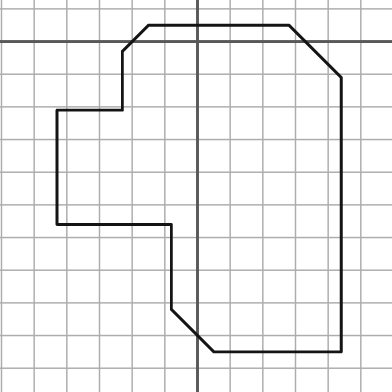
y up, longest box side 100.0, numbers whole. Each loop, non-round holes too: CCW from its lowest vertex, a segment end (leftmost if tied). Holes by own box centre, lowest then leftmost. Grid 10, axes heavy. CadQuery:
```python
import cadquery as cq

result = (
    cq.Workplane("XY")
    .moveTo(5.0, -95.0)
    .lineTo(44.0, -95.0)
    .lineTo(44.0, -11.0)
    .lineTo(28.0, 5.0)
    .lineTo(-15.0, 5.0)
    .lineTo(-23.0, -3.0)
    .lineTo(-23.0, -21.0)
    .lineTo(-43.0, -21.0)
    .lineTo(-43.0, -56.0)
    .lineTo(-8.0, -56.0)
    .lineTo(-8.0, -82.0)
    .close()
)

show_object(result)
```